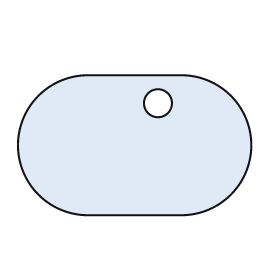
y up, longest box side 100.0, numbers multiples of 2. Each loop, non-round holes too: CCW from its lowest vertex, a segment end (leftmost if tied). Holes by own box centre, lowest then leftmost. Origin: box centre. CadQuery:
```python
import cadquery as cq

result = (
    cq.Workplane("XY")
    .moveTo(-20.0, -30.0)
    .lineTo(20.0, -30.0)
    .threePointArc((50.0, 0.0), (20.0, 30.0))
    .lineTo(-20.0, 30.0)
    .threePointArc((-50.0, 0.0), (-20.0, -30.0))
    .close()
    .moveTo(10.0, 18.0)
    .circle(6.0)
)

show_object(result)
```